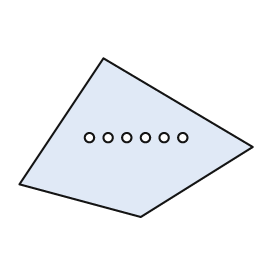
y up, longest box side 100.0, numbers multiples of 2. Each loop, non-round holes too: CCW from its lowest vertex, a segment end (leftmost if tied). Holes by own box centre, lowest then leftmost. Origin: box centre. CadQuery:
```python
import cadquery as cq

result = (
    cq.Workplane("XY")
    .moveTo(2.0, -34.0)
    .lineTo(50.0, -4.0)
    .lineTo(-14.0, 34.0)
    .lineTo(-50.0, -20.0)
    .close()
    .moveTo(-20.0, 0.0)
    .circle(2.0)
    .moveTo(-12.0, 0.0)
    .circle(2.0)
    .moveTo(-4.0, 0.0)
    .circle(2.0)
    .moveTo(4.0, 0.0)
    .circle(2.0)
    .moveTo(12.0, 0.0)
    .circle(2.0)
    .moveTo(20.0, 0.0)
    .circle(2.0)
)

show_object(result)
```